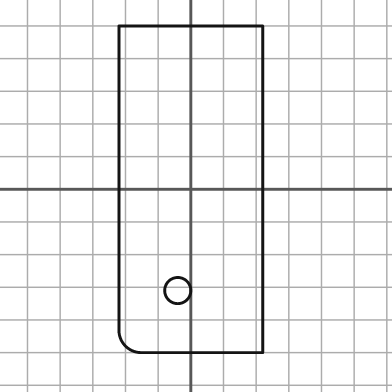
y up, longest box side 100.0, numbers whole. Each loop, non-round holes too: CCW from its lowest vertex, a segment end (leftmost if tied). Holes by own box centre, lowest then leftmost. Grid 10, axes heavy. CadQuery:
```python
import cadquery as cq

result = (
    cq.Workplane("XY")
    .moveTo(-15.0, -50.0)
    .lineTo(22.0, -50.0)
    .lineTo(22.0, 50.0)
    .lineTo(-22.0, 50.0)
    .lineTo(-22.0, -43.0)
    .threePointArc((-20.0, -48.0), (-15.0, -50.0))
    .close()
    .moveTo(-4.0, -31.0)
    .circle(4.0)
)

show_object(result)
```